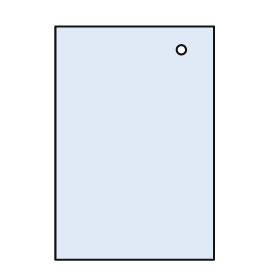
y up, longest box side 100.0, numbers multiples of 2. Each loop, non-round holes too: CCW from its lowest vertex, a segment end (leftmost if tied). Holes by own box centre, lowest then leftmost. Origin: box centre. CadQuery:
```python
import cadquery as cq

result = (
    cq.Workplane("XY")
    .moveTo(-34.0, -50.0)
    .lineTo(34.0, -50.0)
    .lineTo(34.0, 50.0)
    .lineTo(-34.0, 50.0)
    .close()
    .moveTo(20.0, 40.0)
    .circle(2.0)
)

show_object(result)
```